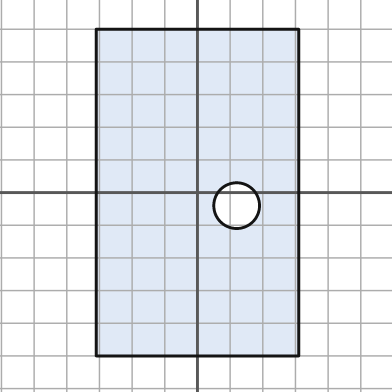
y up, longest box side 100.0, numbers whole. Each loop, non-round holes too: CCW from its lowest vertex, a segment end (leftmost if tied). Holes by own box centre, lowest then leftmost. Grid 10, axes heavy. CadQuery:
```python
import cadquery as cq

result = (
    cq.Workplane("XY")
    .moveTo(-31.0, -50.0)
    .lineTo(31.0, -50.0)
    .lineTo(31.0, 50.0)
    .lineTo(-31.0, 50.0)
    .close()
    .moveTo(12.0, -4.0)
    .circle(7.0)
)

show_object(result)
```